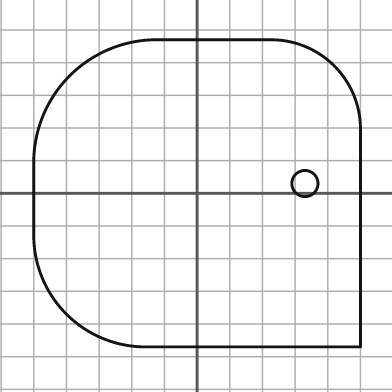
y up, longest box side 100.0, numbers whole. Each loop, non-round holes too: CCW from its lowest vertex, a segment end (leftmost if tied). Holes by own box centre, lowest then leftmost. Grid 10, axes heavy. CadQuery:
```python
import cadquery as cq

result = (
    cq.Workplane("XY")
    .moveTo(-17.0, -47.0)
    .lineTo(50.0, -47.0)
    .lineTo(50.0, 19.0)
    .threePointArc((42.0, 39.0), (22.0, 47.0))
    .lineTo(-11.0, 47.0)
    .threePointArc((-39.0, 36.0), (-50.0, 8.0))
    .lineTo(-50.0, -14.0)
    .threePointArc((-40.0, -37.0), (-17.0, -47.0))
    .close()
    .moveTo(33.0, 3.0)
    .circle(4.0)
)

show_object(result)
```